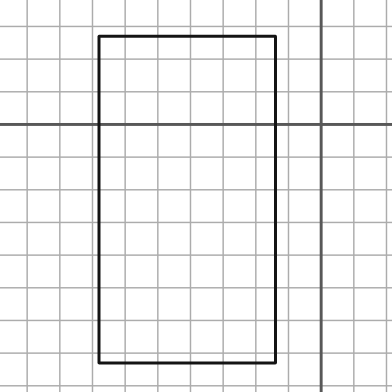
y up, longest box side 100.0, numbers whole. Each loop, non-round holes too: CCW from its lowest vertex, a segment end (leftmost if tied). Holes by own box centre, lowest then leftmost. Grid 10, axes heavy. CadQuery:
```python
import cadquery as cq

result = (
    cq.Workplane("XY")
    .moveTo(-68.0, -73.0)
    .lineTo(-14.0, -73.0)
    .lineTo(-14.0, 27.0)
    .lineTo(-68.0, 27.0)
    .close()
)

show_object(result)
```